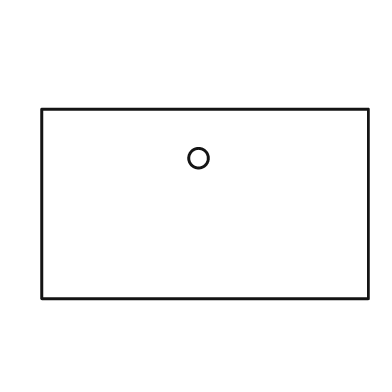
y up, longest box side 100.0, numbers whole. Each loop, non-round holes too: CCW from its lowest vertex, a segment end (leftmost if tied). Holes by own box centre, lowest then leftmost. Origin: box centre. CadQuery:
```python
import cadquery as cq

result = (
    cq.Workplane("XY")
    .moveTo(-50.0, -29.0)
    .lineTo(50.0, -29.0)
    .lineTo(50.0, 29.0)
    .lineTo(-50.0, 29.0)
    .close()
    .moveTo(-2.0, 14.0)
    .circle(3.0)
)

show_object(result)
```